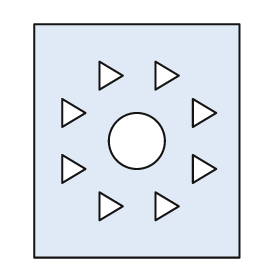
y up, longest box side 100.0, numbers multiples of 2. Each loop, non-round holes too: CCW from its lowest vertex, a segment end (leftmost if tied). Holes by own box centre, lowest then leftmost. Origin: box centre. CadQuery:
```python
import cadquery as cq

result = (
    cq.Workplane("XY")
    .moveTo(-44.0, -50.0)
    .lineTo(44.0, -50.0)
    .lineTo(44.0, 50.0)
    .lineTo(-44.0, 50.0)
    .close()
    .moveTo(-16.0, -34.0)
    .lineTo(-6.0, -28.0)
    .lineTo(-16.0, -22.0)
    .close()
    .moveTo(8.0, -34.0)
    .lineTo(18.0, -28.0)
    .lineTo(8.0, -22.0)
    .close()
    .moveTo(-32.0, -18.0)
    .lineTo(-22.0, -12.0)
    .lineTo(-32.0, -6.0)
    .close()
    .moveTo(24.0, -18.0)
    .lineTo(34.0, -12.0)
    .lineTo(24.0, -6.0)
    .close()
    .moveTo(0.0, 0.0)
    .circle(12.0)
    .moveTo(-32.0, 6.0)
    .lineTo(-22.0, 12.0)
    .lineTo(-32.0, 18.0)
    .close()
    .moveTo(24.0, 6.0)
    .lineTo(34.0, 12.0)
    .lineTo(24.0, 18.0)
    .close()
    .moveTo(-16.0, 22.0)
    .lineTo(-6.0, 28.0)
    .lineTo(-16.0, 34.0)
    .close()
    .moveTo(8.0, 22.0)
    .lineTo(18.0, 28.0)
    .lineTo(8.0, 34.0)
    .close()
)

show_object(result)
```